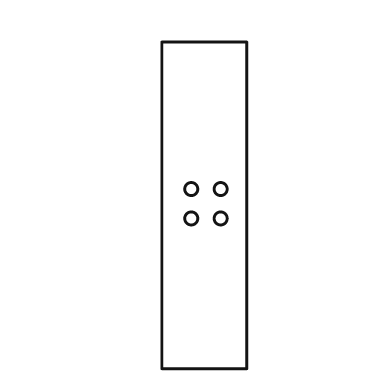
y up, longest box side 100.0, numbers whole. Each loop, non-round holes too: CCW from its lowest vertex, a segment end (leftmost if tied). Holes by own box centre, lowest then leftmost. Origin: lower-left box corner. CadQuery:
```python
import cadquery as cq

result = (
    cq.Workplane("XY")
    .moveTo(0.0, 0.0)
    .lineTo(26.0, 0.0)
    .lineTo(26.0, 100.0)
    .lineTo(0.0, 100.0)
    .close()
    .moveTo(9.0, 46.0)
    .circle(2.0)
    .moveTo(18.0, 46.0)
    .circle(2.0)
    .moveTo(9.0, 55.0)
    .circle(2.0)
    .moveTo(18.0, 55.0)
    .circle(2.0)
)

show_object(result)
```